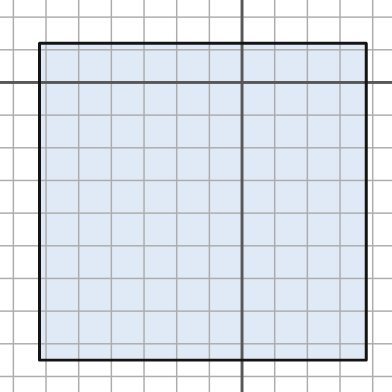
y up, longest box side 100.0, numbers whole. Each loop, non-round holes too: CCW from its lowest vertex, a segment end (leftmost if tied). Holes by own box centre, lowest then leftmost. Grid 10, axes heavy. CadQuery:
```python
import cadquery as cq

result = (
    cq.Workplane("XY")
    .moveTo(-62.0, -85.0)
    .lineTo(38.0, -85.0)
    .lineTo(38.0, 12.0)
    .lineTo(-62.0, 12.0)
    .close()
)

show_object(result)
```